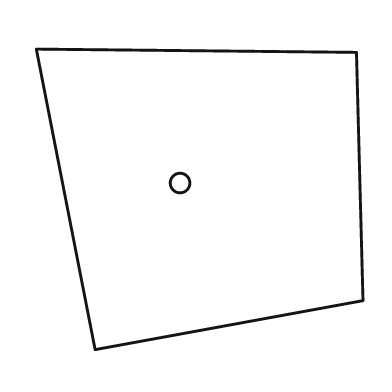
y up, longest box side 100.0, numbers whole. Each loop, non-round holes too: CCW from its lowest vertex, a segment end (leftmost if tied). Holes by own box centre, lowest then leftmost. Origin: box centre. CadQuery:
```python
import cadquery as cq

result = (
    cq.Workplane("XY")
    .moveTo(-32.0, -46.0)
    .lineTo(50.0, -31.0)
    .lineTo(48.0, 45.0)
    .lineTo(-50.0, 46.0)
    .close()
    .moveTo(-6.0, 5.0)
    .circle(3.0)
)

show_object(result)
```